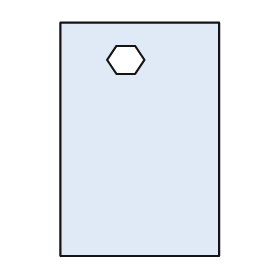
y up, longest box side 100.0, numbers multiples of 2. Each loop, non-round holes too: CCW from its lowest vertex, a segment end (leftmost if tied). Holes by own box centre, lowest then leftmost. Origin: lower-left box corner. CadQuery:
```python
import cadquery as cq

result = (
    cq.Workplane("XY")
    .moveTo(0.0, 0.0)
    .lineTo(68.0, 0.0)
    .lineTo(68.0, 100.0)
    .lineTo(0.0, 100.0)
    .close()
    .moveTo(24.0, 78.0)
    .lineTo(32.0, 78.0)
    .lineTo(36.0, 84.0)
    .lineTo(32.0, 90.0)
    .lineTo(24.0, 90.0)
    .lineTo(20.0, 84.0)
    .close()
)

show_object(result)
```